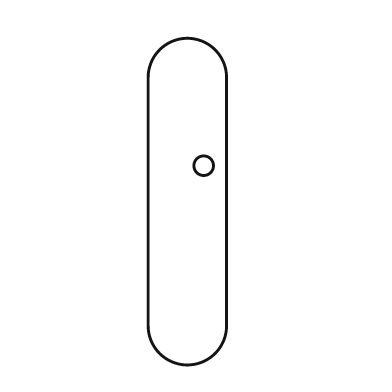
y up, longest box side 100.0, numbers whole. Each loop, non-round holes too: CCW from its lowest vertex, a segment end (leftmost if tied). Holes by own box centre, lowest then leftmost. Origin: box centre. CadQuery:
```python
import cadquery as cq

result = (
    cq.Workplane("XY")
    .moveTo(-12.0, -38.0)
    .threePointArc((0.0, -50.0), (12.0, -38.0))
    .lineTo(12.0, 38.0)
    .threePointArc((0.0, 50.0), (-12.0, 38.0))
    .close()
    .moveTo(5.0, 11.0)
    .circle(3.0)
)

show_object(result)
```